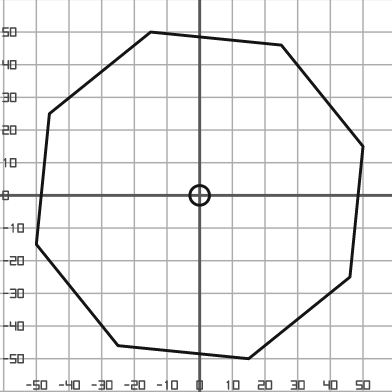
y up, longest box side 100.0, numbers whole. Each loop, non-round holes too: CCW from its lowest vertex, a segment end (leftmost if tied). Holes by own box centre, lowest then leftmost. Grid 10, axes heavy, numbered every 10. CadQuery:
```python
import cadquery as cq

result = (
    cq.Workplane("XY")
    .moveTo(15.0, -50.0)
    .lineTo(46.0, -25.0)
    .lineTo(50.0, 15.0)
    .lineTo(25.0, 46.0)
    .lineTo(-15.0, 50.0)
    .lineTo(-46.0, 25.0)
    .lineTo(-50.0, -15.0)
    .lineTo(-25.0, -46.0)
    .close()
    .moveTo(0.0, 0.0)
    .circle(3.0)
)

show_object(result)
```